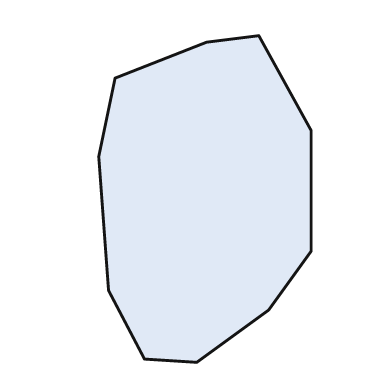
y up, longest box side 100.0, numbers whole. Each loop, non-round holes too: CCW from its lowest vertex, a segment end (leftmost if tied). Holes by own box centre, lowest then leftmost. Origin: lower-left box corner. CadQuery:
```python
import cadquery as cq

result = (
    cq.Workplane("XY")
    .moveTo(30.0, 0.0)
    .lineTo(52.0, 16.0)
    .lineTo(65.0, 34.0)
    .lineTo(65.0, 71.0)
    .lineTo(49.0, 100.0)
    .lineTo(33.0, 98.0)
    .lineTo(5.0, 87.0)
    .lineTo(0.0, 63.0)
    .lineTo(3.0, 22.0)
    .lineTo(14.0, 1.0)
    .close()
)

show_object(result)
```